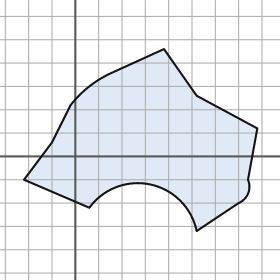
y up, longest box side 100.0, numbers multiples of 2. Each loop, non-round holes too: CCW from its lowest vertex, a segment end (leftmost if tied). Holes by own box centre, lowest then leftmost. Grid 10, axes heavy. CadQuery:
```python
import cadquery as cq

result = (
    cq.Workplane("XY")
    .moveTo(52.0, -32.0)
    .lineTo(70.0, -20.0)
    .threePointArc((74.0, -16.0), (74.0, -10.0))
    .lineTo(78.0, 12.0)
    .lineTo(52.0, 26.0)
    .lineTo(38.0, 46.0)
    .lineTo(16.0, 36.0)
    .threePointArc((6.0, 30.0), (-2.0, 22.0))
    .lineTo(-10.0, 6.0)
    .lineTo(-22.0, -10.0)
    .lineTo(6.0, -22.0)
    .threePointArc((32.0, -12.0), (52.0, -32.0))
    .close()
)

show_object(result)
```